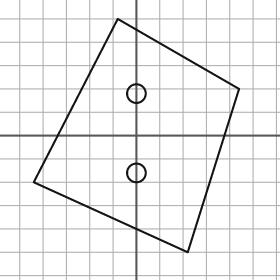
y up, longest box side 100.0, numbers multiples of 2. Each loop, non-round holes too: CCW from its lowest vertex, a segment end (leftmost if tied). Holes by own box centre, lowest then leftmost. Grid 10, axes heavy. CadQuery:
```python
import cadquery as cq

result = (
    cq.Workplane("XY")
    .moveTo(22.0, -50.0)
    .lineTo(44.0, 20.0)
    .lineTo(-8.0, 50.0)
    .lineTo(-44.0, -20.0)
    .close()
    .moveTo(0.0, -16.0)
    .circle(4.0)
    .moveTo(0.0, 18.0)
    .circle(4.0)
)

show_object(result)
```